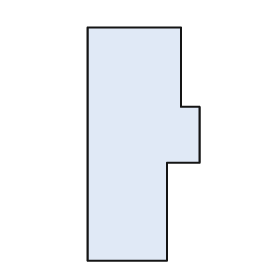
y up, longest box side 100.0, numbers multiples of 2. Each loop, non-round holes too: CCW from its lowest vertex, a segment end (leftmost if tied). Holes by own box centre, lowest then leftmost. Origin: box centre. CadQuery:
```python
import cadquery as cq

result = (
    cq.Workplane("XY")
    .moveTo(-24.0, -50.0)
    .lineTo(10.0, -50.0)
    .lineTo(10.0, -8.0)
    .lineTo(24.0, -8.0)
    .lineTo(24.0, 16.0)
    .lineTo(16.0, 16.0)
    .lineTo(16.0, 50.0)
    .lineTo(-24.0, 50.0)
    .close()
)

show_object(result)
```